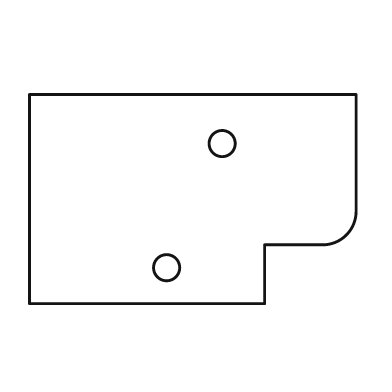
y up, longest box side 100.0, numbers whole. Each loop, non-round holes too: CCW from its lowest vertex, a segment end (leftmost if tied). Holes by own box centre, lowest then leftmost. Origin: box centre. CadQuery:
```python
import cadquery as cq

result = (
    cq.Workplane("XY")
    .moveTo(-50.0, -32.0)
    .lineTo(22.0, -32.0)
    .lineTo(22.0, -14.0)
    .lineTo(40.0, -14.0)
    .threePointArc((47.0, -11.0), (50.0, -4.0))
    .lineTo(50.0, 32.0)
    .lineTo(-50.0, 32.0)
    .close()
    .moveTo(-8.0, -21.0)
    .circle(4.0)
    .moveTo(9.0, 17.0)
    .circle(4.0)
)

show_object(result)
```